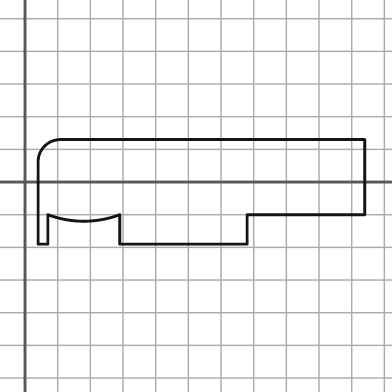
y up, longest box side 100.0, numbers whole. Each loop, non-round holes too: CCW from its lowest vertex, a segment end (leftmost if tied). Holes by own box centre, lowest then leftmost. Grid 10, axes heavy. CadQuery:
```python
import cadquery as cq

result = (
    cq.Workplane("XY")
    .moveTo(4.0, -19.0)
    .lineTo(7.0, -19.0)
    .lineTo(7.0, -10.0)
    .threePointArc((18.0, -12.0), (29.0, -10.0))
    .lineTo(29.0, -19.0)
    .lineTo(68.0, -19.0)
    .lineTo(68.0, -10.0)
    .lineTo(104.0, -10.0)
    .lineTo(104.0, 13.0)
    .lineTo(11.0, 13.0)
    .threePointArc((6.0, 11.0), (4.0, 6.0))
    .close()
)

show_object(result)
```